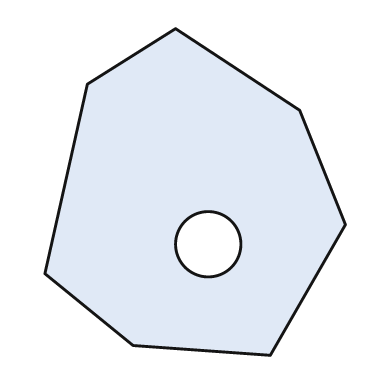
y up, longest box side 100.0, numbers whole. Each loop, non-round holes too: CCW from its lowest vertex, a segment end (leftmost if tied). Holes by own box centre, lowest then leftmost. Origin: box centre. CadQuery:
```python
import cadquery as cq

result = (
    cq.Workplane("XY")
    .moveTo(23.0, -50.0)
    .lineTo(46.0, -10.0)
    .lineTo(32.0, 25.0)
    .lineTo(-6.0, 50.0)
    .lineTo(-33.0, 33.0)
    .lineTo(-46.0, -25.0)
    .lineTo(-19.0, -47.0)
    .close()
    .moveTo(4.0, -16.0)
    .circle(10.0)
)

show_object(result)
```